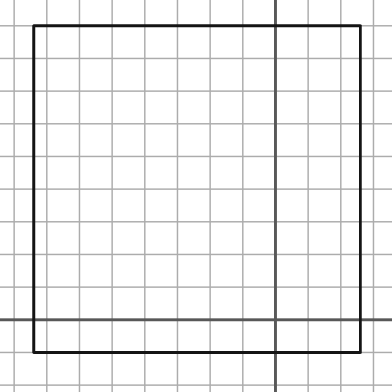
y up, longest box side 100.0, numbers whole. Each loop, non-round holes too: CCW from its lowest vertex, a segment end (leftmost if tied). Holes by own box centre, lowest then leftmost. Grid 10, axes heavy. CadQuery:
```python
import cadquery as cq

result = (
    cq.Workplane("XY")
    .moveTo(-74.0, -10.0)
    .lineTo(26.0, -10.0)
    .lineTo(26.0, 90.0)
    .lineTo(-74.0, 90.0)
    .close()
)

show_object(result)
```